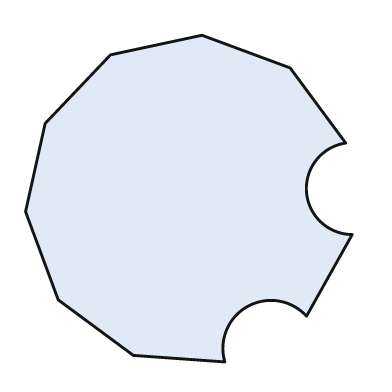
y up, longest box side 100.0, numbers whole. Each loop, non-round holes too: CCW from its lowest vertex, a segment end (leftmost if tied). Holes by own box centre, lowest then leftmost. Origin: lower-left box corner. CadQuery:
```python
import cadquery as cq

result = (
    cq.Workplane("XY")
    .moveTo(61.0, 0.0)
    .threePointArc((68.0, 17.0), (86.0, 14.0))
    .lineTo(100.0, 39.0)
    .threePointArc((86.0, 52.0), (98.0, 67.0))
    .lineTo(81.0, 90.0)
    .lineTo(54.0, 100.0)
    .lineTo(26.0, 94.0)
    .lineTo(6.0, 73.0)
    .lineTo(0.0, 46.0)
    .lineTo(10.0, 19.0)
    .lineTo(33.0, 2.0)
    .close()
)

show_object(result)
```